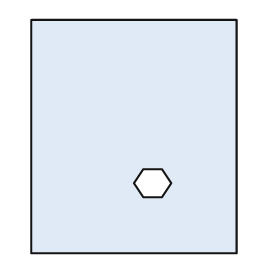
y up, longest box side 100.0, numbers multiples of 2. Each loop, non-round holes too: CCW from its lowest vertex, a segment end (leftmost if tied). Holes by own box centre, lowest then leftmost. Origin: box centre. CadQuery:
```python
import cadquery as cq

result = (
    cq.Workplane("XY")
    .moveTo(-44.0, -50.0)
    .lineTo(44.0, -50.0)
    .lineTo(44.0, 50.0)
    .lineTo(-44.0, 50.0)
    .close()
    .moveTo(4.0, -26.0)
    .lineTo(12.0, -26.0)
    .lineTo(16.0, -20.0)
    .lineTo(12.0, -14.0)
    .lineTo(4.0, -14.0)
    .lineTo(0.0, -20.0)
    .close()
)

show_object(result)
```